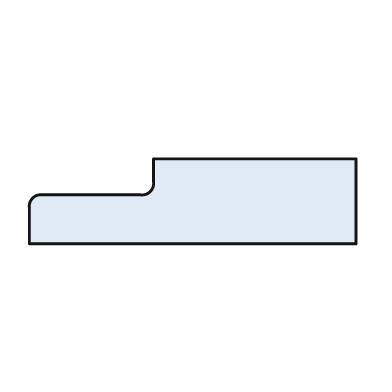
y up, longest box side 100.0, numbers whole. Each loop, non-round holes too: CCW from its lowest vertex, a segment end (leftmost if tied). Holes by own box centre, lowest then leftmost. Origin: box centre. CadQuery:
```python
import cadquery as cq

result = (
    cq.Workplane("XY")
    .moveTo(-50.0, -13.0)
    .lineTo(50.0, -13.0)
    .lineTo(50.0, 13.0)
    .lineTo(-12.0, 13.0)
    .lineTo(-12.0, 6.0)
    .threePointArc((-13.0, 3.0), (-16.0, 2.0))
    .lineTo(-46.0, 2.0)
    .threePointArc((-49.0, 1.0), (-50.0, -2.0))
    .close()
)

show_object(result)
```